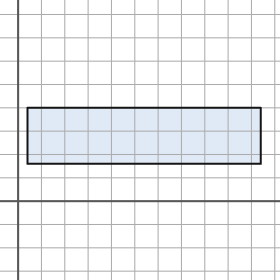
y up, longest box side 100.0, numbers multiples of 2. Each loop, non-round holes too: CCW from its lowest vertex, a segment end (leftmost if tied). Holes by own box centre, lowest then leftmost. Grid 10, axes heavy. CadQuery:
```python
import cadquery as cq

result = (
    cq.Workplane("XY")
    .moveTo(4.0, 16.0)
    .lineTo(104.0, 16.0)
    .lineTo(104.0, 40.0)
    .lineTo(4.0, 40.0)
    .close()
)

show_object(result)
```